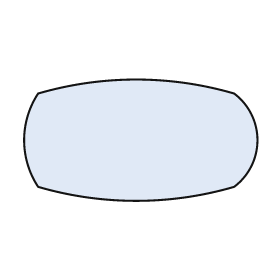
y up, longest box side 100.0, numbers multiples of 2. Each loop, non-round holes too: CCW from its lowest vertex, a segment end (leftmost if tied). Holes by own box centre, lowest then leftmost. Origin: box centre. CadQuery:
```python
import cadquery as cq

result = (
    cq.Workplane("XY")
    .moveTo(-44.0, -20.0)
    .threePointArc((-2.0, -26.0), (40.0, -20.0))
    .threePointArc((50.0, 0.0), (40.0, 20.0))
    .threePointArc((-2.0, 26.0), (-44.0, 20.0))
    .threePointArc((-50.0, 0.0), (-44.0, -20.0))
    .close()
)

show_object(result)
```